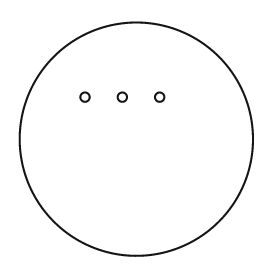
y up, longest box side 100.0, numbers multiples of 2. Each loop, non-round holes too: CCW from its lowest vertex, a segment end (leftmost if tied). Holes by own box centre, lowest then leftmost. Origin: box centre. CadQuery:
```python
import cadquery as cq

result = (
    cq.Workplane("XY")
    .moveTo(0.0, 0.0)
    .circle(50.0)
    .moveTo(-22.0, 18.0)
    .circle(2.0)
    .moveTo(-6.0, 18.0)
    .circle(2.0)
    .moveTo(10.0, 18.0)
    .circle(2.0)
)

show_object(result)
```